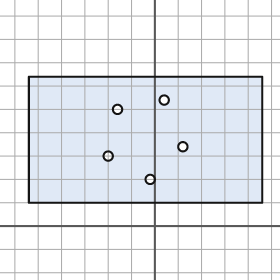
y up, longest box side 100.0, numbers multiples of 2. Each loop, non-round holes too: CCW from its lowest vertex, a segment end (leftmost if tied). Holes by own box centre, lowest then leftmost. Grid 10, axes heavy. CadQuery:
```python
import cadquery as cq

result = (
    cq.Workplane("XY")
    .moveTo(-54.0, 10.0)
    .lineTo(46.0, 10.0)
    .lineTo(46.0, 64.0)
    .lineTo(-54.0, 64.0)
    .close()
    .moveTo(-2.0, 20.0)
    .circle(2.0)
    .moveTo(-20.0, 30.0)
    .circle(2.0)
    .moveTo(12.0, 34.0)
    .circle(2.0)
    .moveTo(-16.0, 50.0)
    .circle(2.0)
    .moveTo(4.0, 54.0)
    .circle(2.0)
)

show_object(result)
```